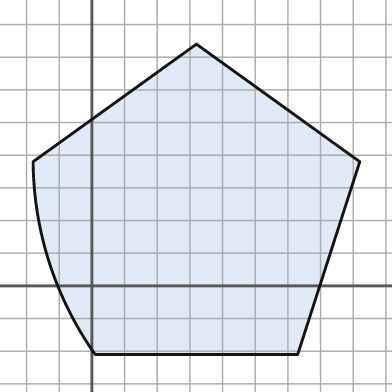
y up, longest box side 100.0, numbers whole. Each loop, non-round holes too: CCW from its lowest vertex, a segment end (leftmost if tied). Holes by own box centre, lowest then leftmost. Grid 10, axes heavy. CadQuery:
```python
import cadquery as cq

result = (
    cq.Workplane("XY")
    .moveTo(1.0, -21.0)
    .lineTo(63.0, -21.0)
    .lineTo(82.0, 38.0)
    .lineTo(32.0, 74.0)
    .lineTo(-18.0, 38.0)
    .threePointArc((-13.0, 7.0), (1.0, -21.0))
    .close()
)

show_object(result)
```